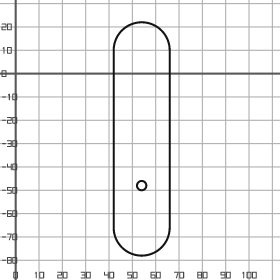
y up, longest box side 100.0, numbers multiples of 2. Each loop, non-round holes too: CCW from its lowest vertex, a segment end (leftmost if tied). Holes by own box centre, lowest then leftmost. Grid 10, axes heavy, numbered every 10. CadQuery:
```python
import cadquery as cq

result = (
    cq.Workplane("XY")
    .moveTo(42.0, -66.0)
    .threePointArc((54.0, -78.0), (66.0, -66.0))
    .lineTo(66.0, 10.0)
    .threePointArc((54.0, 22.0), (42.0, 10.0))
    .close()
    .moveTo(54.0, -48.0)
    .circle(2.0)
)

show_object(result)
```